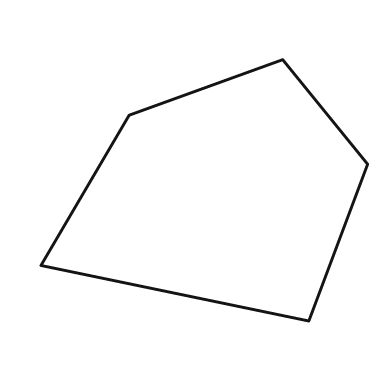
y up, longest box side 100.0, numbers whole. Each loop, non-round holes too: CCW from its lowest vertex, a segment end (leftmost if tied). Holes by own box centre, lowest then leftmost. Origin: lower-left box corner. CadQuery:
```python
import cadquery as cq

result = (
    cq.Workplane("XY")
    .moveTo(82.0, 0.0)
    .lineTo(100.0, 48.0)
    .lineTo(74.0, 80.0)
    .lineTo(27.0, 63.0)
    .lineTo(0.0, 17.0)
    .close()
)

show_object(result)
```